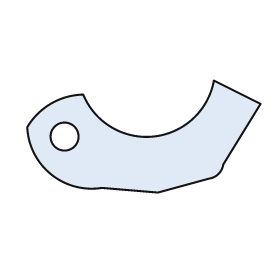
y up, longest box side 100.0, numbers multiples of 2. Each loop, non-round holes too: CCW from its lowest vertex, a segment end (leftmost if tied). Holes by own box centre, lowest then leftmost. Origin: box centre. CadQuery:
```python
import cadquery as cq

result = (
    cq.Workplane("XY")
    .moveTo(6.0, -24.0)
    .lineTo(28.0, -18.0)
    .threePointArc((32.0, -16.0), (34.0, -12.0))
    .lineTo(50.0, 14.0)
    .lineTo(30.0, 24.0)
    .threePointArc((4.0, 0.0), (-26.0, 18.0))
    .threePointArc((-40.0, 14.0), (-50.0, 4.0))
    .threePointArc((-40.0, -16.0), (-18.0, -22.0))
    .close()
    .moveTo(-34.0, 0.0)
    .circle(6.0)
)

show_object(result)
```